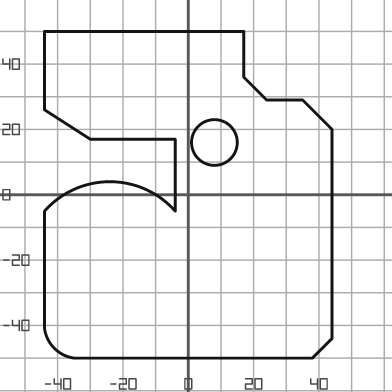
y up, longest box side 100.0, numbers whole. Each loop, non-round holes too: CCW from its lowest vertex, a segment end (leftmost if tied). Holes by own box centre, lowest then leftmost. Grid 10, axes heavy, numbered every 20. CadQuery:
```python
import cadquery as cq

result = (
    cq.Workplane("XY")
    .moveTo(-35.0, -50.0)
    .lineTo(38.0, -50.0)
    .lineTo(44.0, -44.0)
    .lineTo(44.0, 20.0)
    .lineTo(35.0, 29.0)
    .lineTo(24.0, 29.0)
    .lineTo(17.0, 36.0)
    .lineTo(17.0, 50.0)
    .lineTo(-44.0, 50.0)
    .lineTo(-44.0, 26.0)
    .lineTo(-30.0, 17.0)
    .lineTo(-4.0, 17.0)
    .lineTo(-4.0, -5.0)
    .threePointArc((-24.0, 4.0), (-44.0, -5.0))
    .lineTo(-44.0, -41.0)
    .threePointArc((-41.0, -47.0), (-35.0, -50.0))
    .close()
    .moveTo(8.0, 16.0)
    .circle(7.0)
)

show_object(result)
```